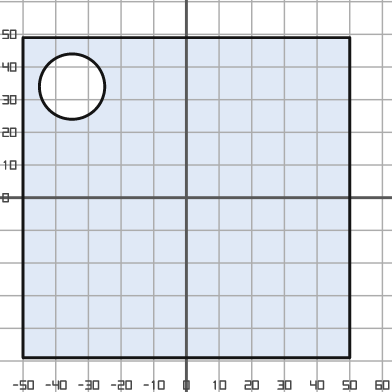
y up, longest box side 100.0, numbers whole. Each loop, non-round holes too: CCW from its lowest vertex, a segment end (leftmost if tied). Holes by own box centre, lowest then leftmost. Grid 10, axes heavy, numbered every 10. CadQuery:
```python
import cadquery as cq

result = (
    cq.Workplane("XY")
    .moveTo(-50.0, -49.0)
    .lineTo(50.0, -49.0)
    .lineTo(50.0, 49.0)
    .lineTo(-50.0, 49.0)
    .close()
    .moveTo(-35.0, 34.0)
    .circle(10.0)
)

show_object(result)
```